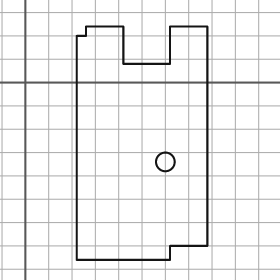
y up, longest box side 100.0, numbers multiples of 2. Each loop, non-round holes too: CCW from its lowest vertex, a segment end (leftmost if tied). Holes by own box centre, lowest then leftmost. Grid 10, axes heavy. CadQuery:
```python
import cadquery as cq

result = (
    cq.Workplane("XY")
    .moveTo(22.0, -76.0)
    .lineTo(62.0, -76.0)
    .lineTo(62.0, -70.0)
    .lineTo(78.0, -70.0)
    .lineTo(78.0, 24.0)
    .lineTo(62.0, 24.0)
    .lineTo(62.0, 8.0)
    .lineTo(42.0, 8.0)
    .lineTo(42.0, 24.0)
    .lineTo(26.0, 24.0)
    .lineTo(26.0, 20.0)
    .lineTo(22.0, 20.0)
    .close()
    .moveTo(60.0, -34.0)
    .circle(4.0)
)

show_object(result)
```